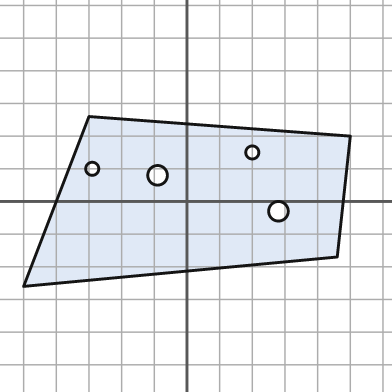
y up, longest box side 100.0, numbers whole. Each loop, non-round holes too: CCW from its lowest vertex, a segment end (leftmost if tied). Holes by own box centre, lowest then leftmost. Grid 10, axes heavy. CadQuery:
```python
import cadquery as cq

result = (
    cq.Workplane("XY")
    .moveTo(-50.0, -26.0)
    .lineTo(46.0, -17.0)
    .lineTo(50.0, 20.0)
    .lineTo(-30.0, 26.0)
    .close()
    .moveTo(28.0, -3.0)
    .circle(3.0)
    .moveTo(-9.0, 8.0)
    .circle(3.0)
    .moveTo(-29.0, 10.0)
    .circle(2.0)
    .moveTo(20.0, 15.0)
    .circle(2.0)
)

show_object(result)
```